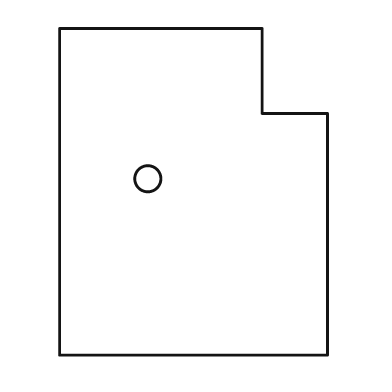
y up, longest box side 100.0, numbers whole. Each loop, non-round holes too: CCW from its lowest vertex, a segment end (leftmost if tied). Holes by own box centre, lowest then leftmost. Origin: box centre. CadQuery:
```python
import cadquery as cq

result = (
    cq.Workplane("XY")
    .moveTo(-41.0, -50.0)
    .lineTo(41.0, -50.0)
    .lineTo(41.0, 24.0)
    .lineTo(21.0, 24.0)
    .lineTo(21.0, 50.0)
    .lineTo(-41.0, 50.0)
    .close()
    .moveTo(-14.0, 4.0)
    .circle(4.0)
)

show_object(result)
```